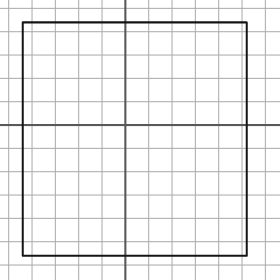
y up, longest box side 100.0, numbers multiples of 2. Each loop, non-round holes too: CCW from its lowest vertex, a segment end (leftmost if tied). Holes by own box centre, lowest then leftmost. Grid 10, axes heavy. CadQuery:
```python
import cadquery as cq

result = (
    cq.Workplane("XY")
    .moveTo(-44.0, -56.0)
    .lineTo(52.0, -56.0)
    .lineTo(52.0, 44.0)
    .lineTo(-44.0, 44.0)
    .close()
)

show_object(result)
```